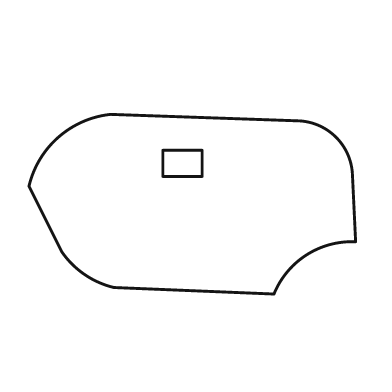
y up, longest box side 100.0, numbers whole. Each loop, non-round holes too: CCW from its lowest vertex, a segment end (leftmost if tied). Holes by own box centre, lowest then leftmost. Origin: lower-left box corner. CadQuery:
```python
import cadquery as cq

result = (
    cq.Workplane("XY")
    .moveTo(75.0, 0.0)
    .threePointArc((85.0, 12.0), (100.0, 16.0))
    .lineTo(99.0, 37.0)
    .threePointArc((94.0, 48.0), (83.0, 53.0))
    .lineTo(25.0, 55.0)
    .threePointArc((9.0, 48.0), (0.0, 33.0))
    .lineTo(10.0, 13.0)
    .threePointArc((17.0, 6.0), (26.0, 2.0))
    .close()
    .moveTo(41.0, 36.0)
    .lineTo(53.0, 36.0)
    .lineTo(53.0, 44.0)
    .lineTo(41.0, 44.0)
    .close()
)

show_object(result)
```